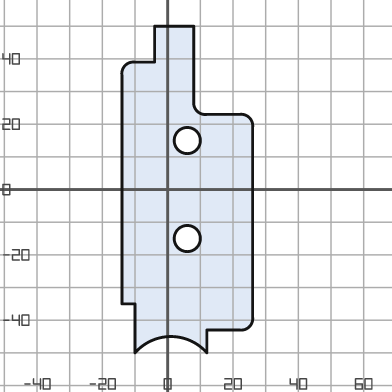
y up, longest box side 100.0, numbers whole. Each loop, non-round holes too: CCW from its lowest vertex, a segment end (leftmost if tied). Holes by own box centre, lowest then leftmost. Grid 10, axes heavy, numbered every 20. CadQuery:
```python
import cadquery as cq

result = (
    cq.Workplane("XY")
    .moveTo(-10.0, -50.0)
    .threePointArc((1.0, -45.0), (12.0, -50.0))
    .lineTo(12.0, -43.0)
    .lineTo(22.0, -43.0)
    .threePointArc((25.0, -42.0), (26.0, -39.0))
    .lineTo(26.0, 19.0)
    .threePointArc((25.0, 22.0), (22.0, 23.0))
    .lineTo(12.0, 23.0)
    .threePointArc((9.0, 24.0), (8.0, 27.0))
    .lineTo(8.0, 50.0)
    .lineTo(-4.0, 50.0)
    .lineTo(-4.0, 39.0)
    .lineTo(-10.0, 39.0)
    .threePointArc((-13.0, 38.0), (-14.0, 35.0))
    .lineTo(-14.0, -35.0)
    .lineTo(-10.0, -35.0)
    .close()
    .moveTo(6.0, -15.0)
    .circle(4.0)
    .moveTo(6.0, 15.0)
    .circle(4.0)
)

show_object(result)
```